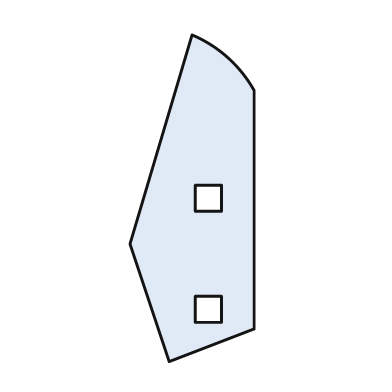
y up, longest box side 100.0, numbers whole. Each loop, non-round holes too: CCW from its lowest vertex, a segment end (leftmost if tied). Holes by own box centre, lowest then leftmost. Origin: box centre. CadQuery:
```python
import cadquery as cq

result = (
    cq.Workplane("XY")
    .moveTo(-7.0, -50.0)
    .lineTo(19.0, -40.0)
    .lineTo(19.0, 33.0)
    .threePointArc((11.0, 43.0), (0.0, 50.0))
    .lineTo(-19.0, -14.0)
    .close()
    .moveTo(1.0, -38.0)
    .lineTo(9.0, -38.0)
    .lineTo(9.0, -30.0)
    .lineTo(1.0, -30.0)
    .close()
    .moveTo(1.0, -4.0)
    .lineTo(9.0, -4.0)
    .lineTo(9.0, 4.0)
    .lineTo(1.0, 4.0)
    .close()
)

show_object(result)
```